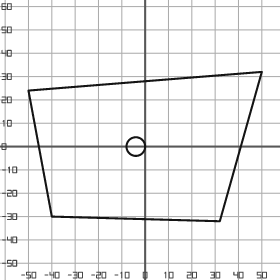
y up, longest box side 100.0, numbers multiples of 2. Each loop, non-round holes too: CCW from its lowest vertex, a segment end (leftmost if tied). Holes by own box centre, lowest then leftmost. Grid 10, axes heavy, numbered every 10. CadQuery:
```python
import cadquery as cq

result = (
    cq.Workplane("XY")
    .moveTo(32.0, -32.0)
    .lineTo(50.0, 32.0)
    .lineTo(-50.0, 24.0)
    .lineTo(-40.0, -30.0)
    .close()
    .moveTo(-4.0, 0.0)
    .circle(4.0)
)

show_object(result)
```